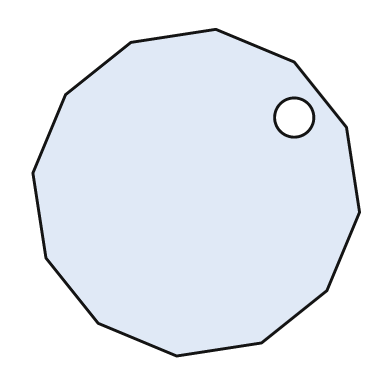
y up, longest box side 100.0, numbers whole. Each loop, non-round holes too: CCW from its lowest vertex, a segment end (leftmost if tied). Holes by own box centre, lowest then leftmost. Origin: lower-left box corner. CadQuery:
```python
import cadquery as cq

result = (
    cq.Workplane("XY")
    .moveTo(44.0, 0.0)
    .lineTo(70.0, 4.0)
    .lineTo(90.0, 20.0)
    .lineTo(100.0, 44.0)
    .lineTo(96.0, 70.0)
    .lineTo(80.0, 90.0)
    .lineTo(56.0, 100.0)
    .lineTo(30.0, 96.0)
    .lineTo(10.0, 80.0)
    .lineTo(0.0, 56.0)
    .lineTo(4.0, 30.0)
    .lineTo(20.0, 10.0)
    .close()
    .moveTo(80.0, 73.0)
    .circle(6.0)
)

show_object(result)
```